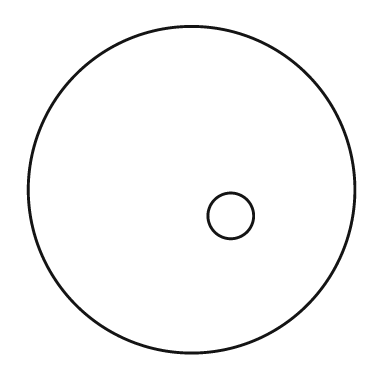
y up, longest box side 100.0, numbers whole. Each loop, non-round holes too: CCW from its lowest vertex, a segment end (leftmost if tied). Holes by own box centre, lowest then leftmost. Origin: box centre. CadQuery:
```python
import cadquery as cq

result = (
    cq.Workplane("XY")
    .moveTo(0.0, 0.0)
    .circle(50.0)
    .moveTo(12.0, -8.0)
    .circle(7.0)
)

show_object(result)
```